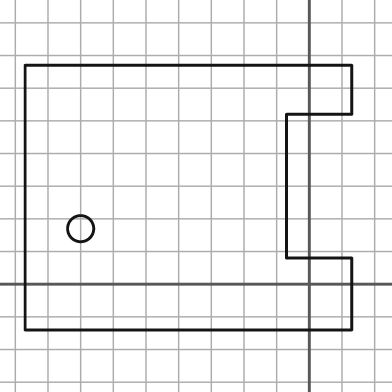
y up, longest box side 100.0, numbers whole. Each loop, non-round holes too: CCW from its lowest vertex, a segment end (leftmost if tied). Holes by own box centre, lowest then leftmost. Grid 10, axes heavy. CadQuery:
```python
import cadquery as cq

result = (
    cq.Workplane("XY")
    .moveTo(-87.0, -14.0)
    .lineTo(13.0, -14.0)
    .lineTo(13.0, 8.0)
    .lineTo(-7.0, 8.0)
    .lineTo(-7.0, 52.0)
    .lineTo(13.0, 52.0)
    .lineTo(13.0, 67.0)
    .lineTo(-87.0, 67.0)
    .close()
    .moveTo(-70.0, 17.0)
    .circle(4.0)
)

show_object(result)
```